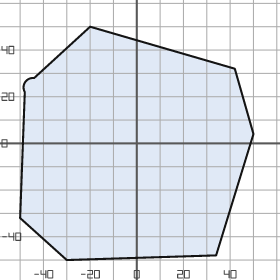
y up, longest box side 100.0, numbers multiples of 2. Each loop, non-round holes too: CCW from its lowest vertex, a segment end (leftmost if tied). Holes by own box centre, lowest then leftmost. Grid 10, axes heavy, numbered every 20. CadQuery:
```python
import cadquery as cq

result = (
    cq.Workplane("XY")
    .moveTo(-30.0, -50.0)
    .lineTo(34.0, -48.0)
    .lineTo(50.0, 4.0)
    .lineTo(42.0, 32.0)
    .lineTo(-20.0, 50.0)
    .lineTo(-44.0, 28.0)
    .threePointArc((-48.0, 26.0), (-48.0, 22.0))
    .lineTo(-50.0, -32.0)
    .close()
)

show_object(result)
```